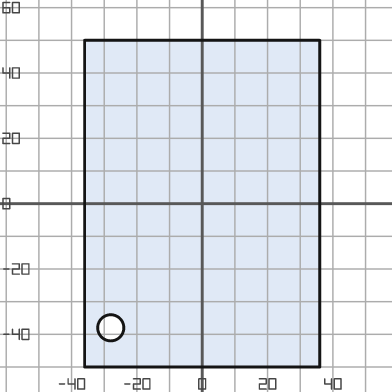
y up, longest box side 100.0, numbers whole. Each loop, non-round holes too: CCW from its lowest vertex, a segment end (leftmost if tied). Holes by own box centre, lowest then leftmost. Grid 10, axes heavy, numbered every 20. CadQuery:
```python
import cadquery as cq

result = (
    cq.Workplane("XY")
    .moveTo(-36.0, -50.0)
    .lineTo(36.0, -50.0)
    .lineTo(36.0, 50.0)
    .lineTo(-36.0, 50.0)
    .close()
    .moveTo(-28.0, -38.0)
    .circle(4.0)
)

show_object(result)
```